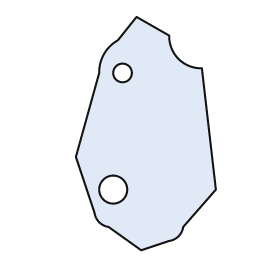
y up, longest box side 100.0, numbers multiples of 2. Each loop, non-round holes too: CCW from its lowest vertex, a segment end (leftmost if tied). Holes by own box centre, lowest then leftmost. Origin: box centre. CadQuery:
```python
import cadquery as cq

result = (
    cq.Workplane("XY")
    .moveTo(-2.0, -50.0)
    .lineTo(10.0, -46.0)
    .threePointArc((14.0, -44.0), (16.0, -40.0))
    .lineTo(30.0, -24.0)
    .lineTo(24.0, 28.0)
    .threePointArc((14.0, 32.0), (10.0, 42.0))
    .lineTo(-4.0, 50.0)
    .lineTo(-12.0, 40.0)
    .threePointArc((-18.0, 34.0), (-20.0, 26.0))
    .lineTo(-30.0, -10.0)
    .lineTo(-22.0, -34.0)
    .threePointArc((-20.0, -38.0), (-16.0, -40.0))
    .close()
    .moveTo(-14.0, -24.0)
    .circle(6.0)
    .moveTo(-10.0, 26.0)
    .circle(4.0)
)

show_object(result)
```